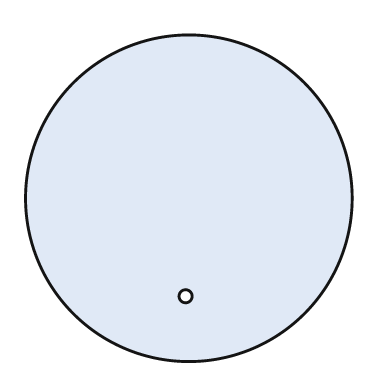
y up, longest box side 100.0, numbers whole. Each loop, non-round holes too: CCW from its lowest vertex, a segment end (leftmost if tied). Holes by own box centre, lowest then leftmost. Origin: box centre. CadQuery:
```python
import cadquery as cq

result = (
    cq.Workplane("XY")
    .moveTo(0.0, 0.0)
    .circle(50.0)
    .moveTo(-1.0, -30.0)
    .circle(2.0)
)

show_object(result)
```